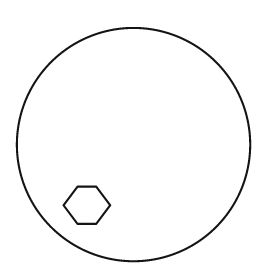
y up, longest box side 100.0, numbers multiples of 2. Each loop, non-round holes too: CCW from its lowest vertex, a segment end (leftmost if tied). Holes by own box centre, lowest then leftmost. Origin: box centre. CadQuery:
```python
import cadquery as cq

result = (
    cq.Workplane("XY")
    .moveTo(0.0, 0.0)
    .circle(50.0)
    .moveTo(-24.0, -34.0)
    .lineTo(-16.0, -34.0)
    .lineTo(-10.0, -26.0)
    .lineTo(-16.0, -18.0)
    .lineTo(-24.0, -18.0)
    .lineTo(-30.0, -26.0)
    .close()
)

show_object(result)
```